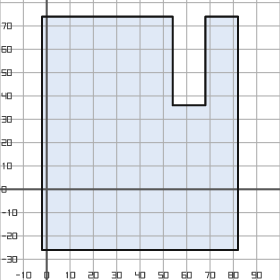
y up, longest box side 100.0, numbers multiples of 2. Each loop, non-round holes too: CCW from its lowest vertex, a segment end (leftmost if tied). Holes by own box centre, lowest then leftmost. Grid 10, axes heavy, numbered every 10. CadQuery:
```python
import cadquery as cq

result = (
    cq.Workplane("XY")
    .moveTo(-2.0, -26.0)
    .lineTo(82.0, -26.0)
    .lineTo(82.0, 74.0)
    .lineTo(68.0, 74.0)
    .lineTo(68.0, 36.0)
    .lineTo(54.0, 36.0)
    .lineTo(54.0, 74.0)
    .lineTo(-2.0, 74.0)
    .close()
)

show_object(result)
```